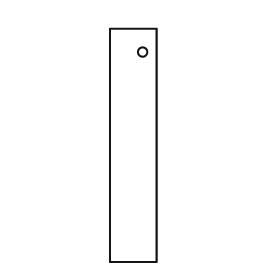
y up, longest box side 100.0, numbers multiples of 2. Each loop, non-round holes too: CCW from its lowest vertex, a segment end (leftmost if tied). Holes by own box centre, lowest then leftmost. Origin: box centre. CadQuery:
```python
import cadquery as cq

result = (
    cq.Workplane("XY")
    .moveTo(-10.0, -50.0)
    .lineTo(10.0, -50.0)
    .lineTo(10.0, 50.0)
    .lineTo(-10.0, 50.0)
    .close()
    .moveTo(4.0, 40.0)
    .circle(2.0)
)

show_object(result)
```